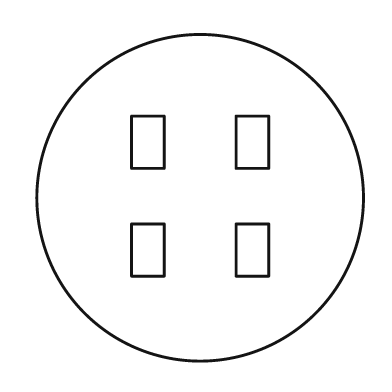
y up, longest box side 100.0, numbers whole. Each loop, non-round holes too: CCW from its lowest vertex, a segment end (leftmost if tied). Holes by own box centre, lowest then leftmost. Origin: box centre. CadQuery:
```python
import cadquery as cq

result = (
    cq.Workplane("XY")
    .moveTo(0.0, 0.0)
    .circle(50.0)
    .moveTo(-21.0, -24.0)
    .lineTo(-11.0, -24.0)
    .lineTo(-11.0, -8.0)
    .lineTo(-21.0, -8.0)
    .close()
    .moveTo(11.0, -24.0)
    .lineTo(21.0, -24.0)
    .lineTo(21.0, -8.0)
    .lineTo(11.0, -8.0)
    .close()
    .moveTo(-21.0, 9.0)
    .lineTo(-11.0, 9.0)
    .lineTo(-11.0, 25.0)
    .lineTo(-21.0, 25.0)
    .close()
    .moveTo(11.0, 9.0)
    .lineTo(21.0, 9.0)
    .lineTo(21.0, 25.0)
    .lineTo(11.0, 25.0)
    .close()
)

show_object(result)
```